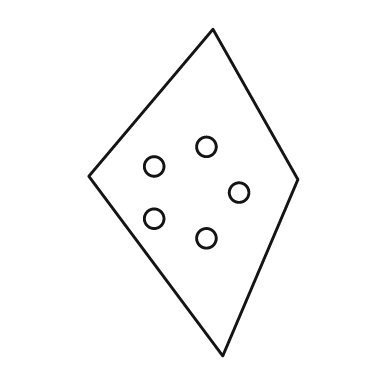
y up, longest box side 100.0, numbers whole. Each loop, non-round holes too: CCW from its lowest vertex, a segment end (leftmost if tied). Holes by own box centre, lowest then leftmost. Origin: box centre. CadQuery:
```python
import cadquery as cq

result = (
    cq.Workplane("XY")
    .moveTo(9.0, -50.0)
    .lineTo(32.0, 4.0)
    .lineTo(6.0, 50.0)
    .lineTo(-32.0, 5.0)
    .close()
    .moveTo(4.0, -14.0)
    .circle(3.0)
    .moveTo(-12.0, -8.0)
    .circle(3.0)
    .moveTo(14.0, 0.0)
    .circle(3.0)
    .moveTo(-12.0, 8.0)
    .circle(3.0)
    .moveTo(4.0, 14.0)
    .circle(3.0)
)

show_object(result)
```